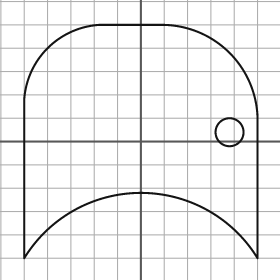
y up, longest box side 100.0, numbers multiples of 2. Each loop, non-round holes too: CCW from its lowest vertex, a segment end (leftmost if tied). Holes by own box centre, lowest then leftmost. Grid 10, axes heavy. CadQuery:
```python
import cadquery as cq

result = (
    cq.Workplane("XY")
    .moveTo(-50.0, -50.0)
    .threePointArc((0.0, -22.0), (50.0, -50.0))
    .lineTo(50.0, 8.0)
    .threePointArc((38.0, 38.0), (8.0, 50.0))
    .lineTo(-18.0, 50.0)
    .threePointArc((-40.0, 40.0), (-50.0, 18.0))
    .close()
    .moveTo(38.0, 4.0)
    .circle(6.0)
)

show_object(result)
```